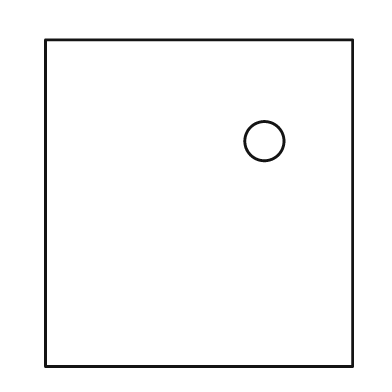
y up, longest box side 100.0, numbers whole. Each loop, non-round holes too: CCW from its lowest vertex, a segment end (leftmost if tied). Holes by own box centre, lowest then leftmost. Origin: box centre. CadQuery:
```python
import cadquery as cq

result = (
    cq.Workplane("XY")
    .moveTo(-47.0, -50.0)
    .lineTo(47.0, -50.0)
    .lineTo(47.0, 50.0)
    .lineTo(-47.0, 50.0)
    .close()
    .moveTo(20.0, 19.0)
    .circle(6.0)
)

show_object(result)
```